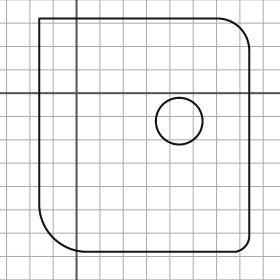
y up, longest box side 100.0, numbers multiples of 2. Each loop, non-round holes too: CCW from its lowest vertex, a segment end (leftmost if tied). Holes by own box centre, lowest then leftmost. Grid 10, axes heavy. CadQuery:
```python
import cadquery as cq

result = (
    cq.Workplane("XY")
    .moveTo(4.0, -68.0)
    .lineTo(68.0, -68.0)
    .threePointArc((72.0, -66.0), (74.0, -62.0))
    .lineTo(74.0, 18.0)
    .threePointArc((70.0, 28.0), (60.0, 32.0))
    .lineTo(-16.0, 32.0)
    .lineTo(-16.0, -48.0)
    .threePointArc((-10.0, -62.0), (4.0, -68.0))
    .close()
    .moveTo(44.0, -12.0)
    .circle(10.0)
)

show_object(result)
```